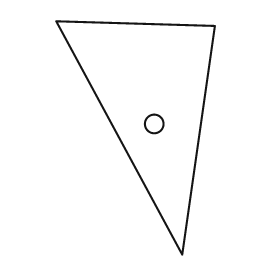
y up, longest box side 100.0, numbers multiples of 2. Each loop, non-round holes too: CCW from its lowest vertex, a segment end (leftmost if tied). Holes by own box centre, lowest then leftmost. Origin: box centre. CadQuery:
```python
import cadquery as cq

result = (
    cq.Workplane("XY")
    .moveTo(20.0, -50.0)
    .lineTo(34.0, 48.0)
    .lineTo(-34.0, 50.0)
    .close()
    .moveTo(8.0, 6.0)
    .circle(4.0)
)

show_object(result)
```